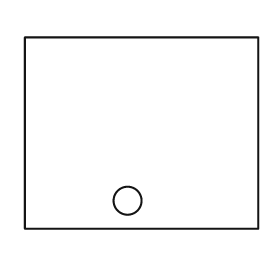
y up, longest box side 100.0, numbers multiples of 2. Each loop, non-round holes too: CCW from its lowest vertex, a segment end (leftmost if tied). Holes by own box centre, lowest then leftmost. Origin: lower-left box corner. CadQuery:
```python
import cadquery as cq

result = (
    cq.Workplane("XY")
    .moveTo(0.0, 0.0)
    .lineTo(100.0, 0.0)
    .lineTo(100.0, 82.0)
    .lineTo(0.0, 82.0)
    .close()
    .moveTo(44.0, 12.0)
    .circle(6.0)
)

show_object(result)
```